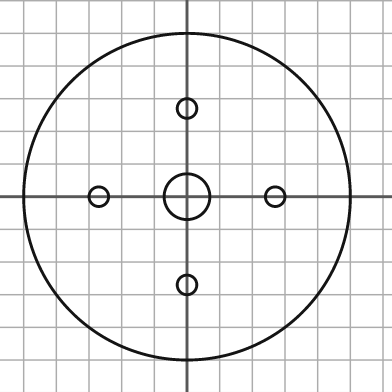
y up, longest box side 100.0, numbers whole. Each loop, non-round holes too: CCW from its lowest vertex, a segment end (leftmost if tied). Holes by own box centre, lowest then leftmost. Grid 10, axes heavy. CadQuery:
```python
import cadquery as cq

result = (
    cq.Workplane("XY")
    .moveTo(0.0, 0.0)
    .circle(50.0)
    .moveTo(0.0, -27.0)
    .circle(3.0)
    .moveTo(-27.0, 0.0)
    .circle(3.0)
    .moveTo(0.0, 0.0)
    .circle(7.0)
    .moveTo(27.0, 0.0)
    .circle(3.0)
    .moveTo(0.0, 27.0)
    .circle(3.0)
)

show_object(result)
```